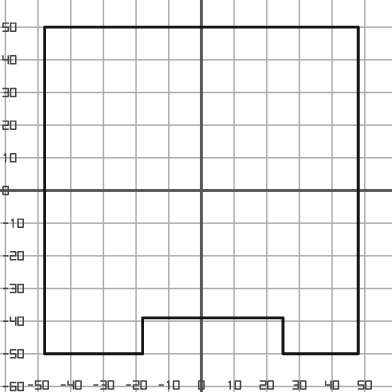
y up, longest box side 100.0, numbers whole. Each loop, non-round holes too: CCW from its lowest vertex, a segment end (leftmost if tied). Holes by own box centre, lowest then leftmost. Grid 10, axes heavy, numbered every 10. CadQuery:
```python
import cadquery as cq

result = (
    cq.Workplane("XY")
    .moveTo(-48.0, -50.0)
    .lineTo(-18.0, -50.0)
    .lineTo(-18.0, -39.0)
    .lineTo(25.0, -39.0)
    .lineTo(25.0, -50.0)
    .lineTo(48.0, -50.0)
    .lineTo(48.0, 50.0)
    .lineTo(-48.0, 50.0)
    .close()
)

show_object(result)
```